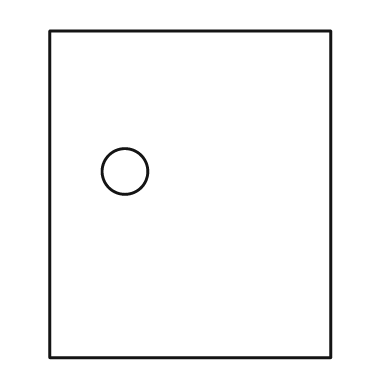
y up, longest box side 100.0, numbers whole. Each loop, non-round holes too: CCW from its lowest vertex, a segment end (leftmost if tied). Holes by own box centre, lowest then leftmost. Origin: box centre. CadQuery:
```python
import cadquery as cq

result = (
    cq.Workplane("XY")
    .moveTo(-43.0, -50.0)
    .lineTo(43.0, -50.0)
    .lineTo(43.0, 50.0)
    .lineTo(-43.0, 50.0)
    .close()
    .moveTo(-20.0, 7.0)
    .circle(7.0)
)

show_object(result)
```